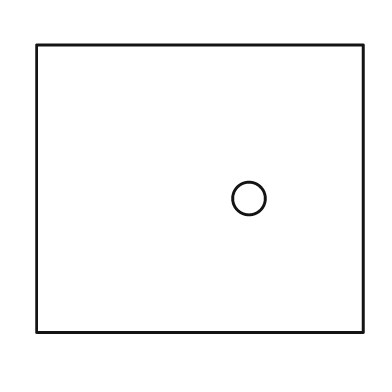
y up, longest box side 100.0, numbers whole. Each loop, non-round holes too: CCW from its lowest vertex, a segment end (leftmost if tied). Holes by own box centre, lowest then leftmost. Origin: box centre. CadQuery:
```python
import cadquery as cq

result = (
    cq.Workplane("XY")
    .moveTo(-50.0, -44.0)
    .lineTo(50.0, -44.0)
    .lineTo(50.0, 44.0)
    .lineTo(-50.0, 44.0)
    .close()
    .moveTo(15.0, -3.0)
    .circle(5.0)
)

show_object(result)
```